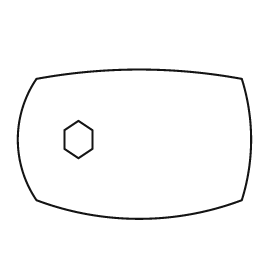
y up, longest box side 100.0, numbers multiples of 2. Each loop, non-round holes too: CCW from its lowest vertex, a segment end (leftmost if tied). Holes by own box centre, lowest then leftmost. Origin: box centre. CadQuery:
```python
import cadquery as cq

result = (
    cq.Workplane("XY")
    .moveTo(-42.0, -24.0)
    .threePointArc((2.0, -32.0), (46.0, -24.0))
    .threePointArc((50.0, 2.0), (46.0, 28.0))
    .threePointArc((2.0, 32.0), (-42.0, 28.0))
    .threePointArc((-50.0, 2.0), (-42.0, -24.0))
    .close()
    .moveTo(-24.0, -6.0)
    .lineTo(-18.0, -2.0)
    .lineTo(-18.0, 6.0)
    .lineTo(-24.0, 10.0)
    .lineTo(-30.0, 6.0)
    .lineTo(-30.0, -2.0)
    .close()
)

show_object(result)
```